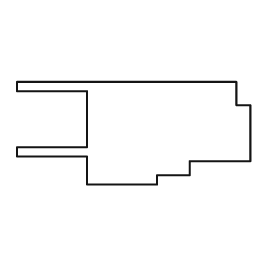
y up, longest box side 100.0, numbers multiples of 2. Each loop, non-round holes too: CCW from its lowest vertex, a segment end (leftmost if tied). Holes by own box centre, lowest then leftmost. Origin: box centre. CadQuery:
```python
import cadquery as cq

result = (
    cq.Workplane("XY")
    .moveTo(-20.0, -22.0)
    .lineTo(10.0, -22.0)
    .lineTo(10.0, -18.0)
    .lineTo(24.0, -18.0)
    .lineTo(24.0, -12.0)
    .lineTo(50.0, -12.0)
    .lineTo(50.0, 12.0)
    .lineTo(44.0, 12.0)
    .lineTo(44.0, 22.0)
    .lineTo(-50.0, 22.0)
    .lineTo(-50.0, 18.0)
    .lineTo(-20.0, 18.0)
    .lineTo(-20.0, -6.0)
    .lineTo(-50.0, -6.0)
    .lineTo(-50.0, -10.0)
    .lineTo(-20.0, -10.0)
    .close()
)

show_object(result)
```